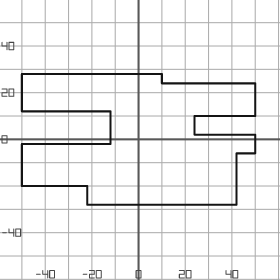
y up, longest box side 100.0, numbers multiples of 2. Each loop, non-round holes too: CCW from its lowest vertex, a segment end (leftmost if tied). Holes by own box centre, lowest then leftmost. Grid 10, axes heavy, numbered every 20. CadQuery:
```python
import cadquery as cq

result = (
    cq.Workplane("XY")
    .moveTo(-22.0, -28.0)
    .lineTo(42.0, -28.0)
    .lineTo(42.0, -6.0)
    .lineTo(50.0, -6.0)
    .lineTo(50.0, 2.0)
    .lineTo(24.0, 2.0)
    .lineTo(24.0, 10.0)
    .lineTo(50.0, 10.0)
    .lineTo(50.0, 24.0)
    .lineTo(10.0, 24.0)
    .lineTo(10.0, 28.0)
    .lineTo(-50.0, 28.0)
    .lineTo(-50.0, 12.0)
    .lineTo(-12.0, 12.0)
    .lineTo(-12.0, -2.0)
    .lineTo(-50.0, -2.0)
    .lineTo(-50.0, -20.0)
    .lineTo(-22.0, -20.0)
    .close()
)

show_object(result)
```